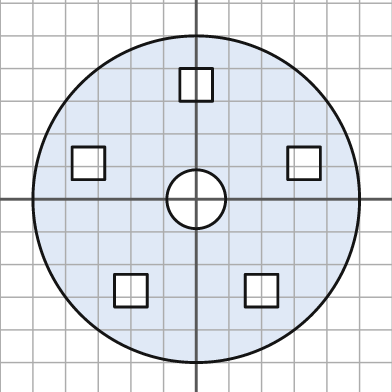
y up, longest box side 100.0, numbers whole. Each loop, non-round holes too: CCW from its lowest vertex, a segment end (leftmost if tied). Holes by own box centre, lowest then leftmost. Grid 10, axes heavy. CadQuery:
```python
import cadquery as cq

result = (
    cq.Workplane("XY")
    .moveTo(0.0, 0.0)
    .circle(50.0)
    .moveTo(-25.0, -33.0)
    .lineTo(-15.0, -33.0)
    .lineTo(-15.0, -23.0)
    .lineTo(-25.0, -23.0)
    .close()
    .moveTo(15.0, -33.0)
    .lineTo(25.0, -33.0)
    .lineTo(25.0, -23.0)
    .lineTo(15.0, -23.0)
    .close()
    .moveTo(0.0, 0.0)
    .circle(9.0)
    .moveTo(-38.0, 6.0)
    .lineTo(-28.0, 6.0)
    .lineTo(-28.0, 16.0)
    .lineTo(-38.0, 16.0)
    .close()
    .moveTo(28.0, 6.0)
    .lineTo(38.0, 6.0)
    .lineTo(38.0, 16.0)
    .lineTo(28.0, 16.0)
    .close()
    .moveTo(-5.0, 30.0)
    .lineTo(5.0, 30.0)
    .lineTo(5.0, 40.0)
    .lineTo(-5.0, 40.0)
    .close()
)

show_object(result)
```